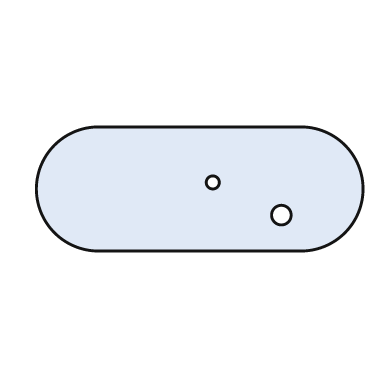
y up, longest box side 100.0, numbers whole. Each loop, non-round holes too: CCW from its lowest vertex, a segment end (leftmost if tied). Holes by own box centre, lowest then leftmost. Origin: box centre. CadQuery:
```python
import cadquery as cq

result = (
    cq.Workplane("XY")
    .moveTo(-31.0, -19.0)
    .lineTo(31.0, -19.0)
    .threePointArc((50.0, 0.0), (31.0, 19.0))
    .lineTo(-31.0, 19.0)
    .threePointArc((-50.0, 0.0), (-31.0, -19.0))
    .close()
    .moveTo(25.0, -8.0)
    .circle(3.0)
    .moveTo(4.0, 2.0)
    .circle(2.0)
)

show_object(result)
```